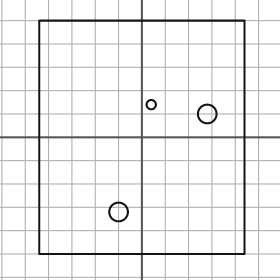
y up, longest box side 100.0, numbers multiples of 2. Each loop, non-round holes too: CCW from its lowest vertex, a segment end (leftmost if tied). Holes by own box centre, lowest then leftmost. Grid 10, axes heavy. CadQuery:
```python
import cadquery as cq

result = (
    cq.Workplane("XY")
    .moveTo(-44.0, -50.0)
    .lineTo(44.0, -50.0)
    .lineTo(44.0, 50.0)
    .lineTo(-44.0, 50.0)
    .close()
    .moveTo(-10.0, -32.0)
    .circle(4.0)
    .moveTo(28.0, 10.0)
    .circle(4.0)
    .moveTo(4.0, 14.0)
    .circle(2.0)
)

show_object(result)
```